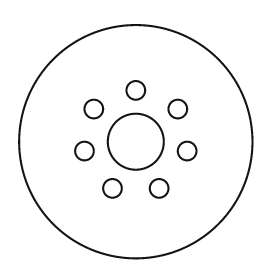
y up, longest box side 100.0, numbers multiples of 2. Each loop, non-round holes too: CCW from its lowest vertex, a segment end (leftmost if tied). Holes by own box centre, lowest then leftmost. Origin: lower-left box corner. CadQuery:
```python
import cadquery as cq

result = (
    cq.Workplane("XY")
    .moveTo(50.0, 50.0)
    .circle(50.0)
    .moveTo(40.0, 30.0)
    .circle(4.0)
    .moveTo(60.0, 30.0)
    .circle(4.0)
    .moveTo(28.0, 46.0)
    .circle(4.0)
    .moveTo(72.0, 46.0)
    .circle(4.0)
    .moveTo(50.0, 50.0)
    .circle(12.0)
    .moveTo(32.0, 64.0)
    .circle(4.0)
    .moveTo(68.0, 64.0)
    .circle(4.0)
    .moveTo(50.0, 72.0)
    .circle(4.0)
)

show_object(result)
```